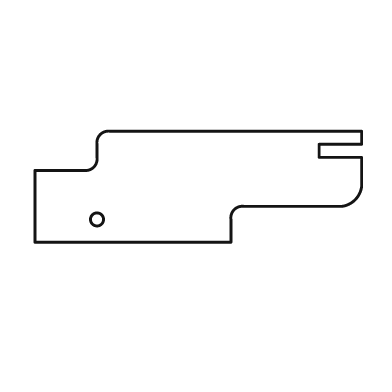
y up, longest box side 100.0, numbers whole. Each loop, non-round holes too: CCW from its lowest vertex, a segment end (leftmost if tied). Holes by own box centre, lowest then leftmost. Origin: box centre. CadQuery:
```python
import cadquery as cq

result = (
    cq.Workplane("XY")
    .moveTo(-50.0, -17.0)
    .lineTo(10.0, -17.0)
    .lineTo(10.0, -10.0)
    .threePointArc((11.0, -7.0), (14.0, -6.0))
    .lineTo(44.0, -6.0)
    .threePointArc((48.0, -4.0), (50.0, 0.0))
    .lineTo(50.0, 9.0)
    .lineTo(37.0, 9.0)
    .lineTo(37.0, 13.0)
    .lineTo(50.0, 13.0)
    .lineTo(50.0, 17.0)
    .lineTo(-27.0, 17.0)
    .threePointArc((-30.0, 16.0), (-31.0, 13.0))
    .lineTo(-31.0, 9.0)
    .threePointArc((-32.0, 6.0), (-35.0, 5.0))
    .lineTo(-50.0, 5.0)
    .close()
    .moveTo(-31.0, -10.0)
    .circle(2.0)
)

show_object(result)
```